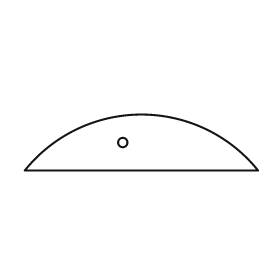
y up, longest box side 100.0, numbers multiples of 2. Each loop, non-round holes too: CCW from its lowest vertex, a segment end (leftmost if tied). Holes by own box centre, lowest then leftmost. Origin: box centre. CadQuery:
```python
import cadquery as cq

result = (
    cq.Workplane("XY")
    .moveTo(-50.0, -12.0)
    .lineTo(50.0, -12.0)
    .threePointArc((0.0, 12.0), (-50.0, -12.0))
    .close()
    .moveTo(-8.0, 0.0)
    .circle(2.0)
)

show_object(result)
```